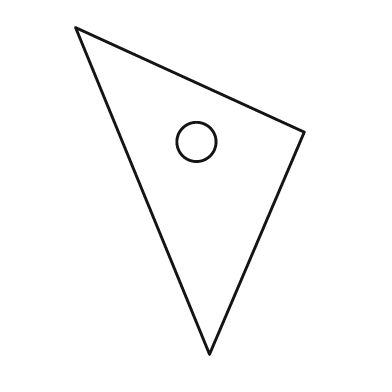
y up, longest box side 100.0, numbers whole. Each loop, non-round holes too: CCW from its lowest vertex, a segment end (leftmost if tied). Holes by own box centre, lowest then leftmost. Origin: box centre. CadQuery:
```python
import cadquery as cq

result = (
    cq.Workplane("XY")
    .moveTo(6.0, -50.0)
    .lineTo(35.0, 18.0)
    .lineTo(-35.0, 50.0)
    .close()
    .moveTo(2.0, 15.0)
    .circle(6.0)
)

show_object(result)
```